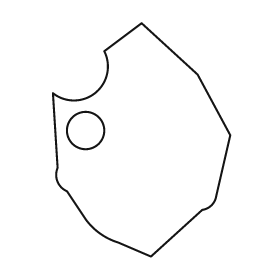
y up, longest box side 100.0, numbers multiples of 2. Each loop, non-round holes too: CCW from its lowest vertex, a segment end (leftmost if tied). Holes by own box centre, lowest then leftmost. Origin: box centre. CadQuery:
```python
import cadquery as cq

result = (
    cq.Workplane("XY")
    .moveTo(4.0, -50.0)
    .lineTo(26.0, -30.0)
    .threePointArc((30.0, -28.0), (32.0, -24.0))
    .lineTo(38.0, 2.0)
    .lineTo(24.0, 28.0)
    .lineTo(0.0, 50.0)
    .lineTo(-16.0, 38.0)
    .threePointArc((-20.0, 20.0), (-38.0, 20.0))
    .lineTo(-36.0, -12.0)
    .threePointArc((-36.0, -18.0), (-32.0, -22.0))
    .lineTo(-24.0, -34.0)
    .threePointArc((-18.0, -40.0), (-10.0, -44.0))
    .close()
    .moveTo(-24.0, 4.0)
    .circle(8.0)
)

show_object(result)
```